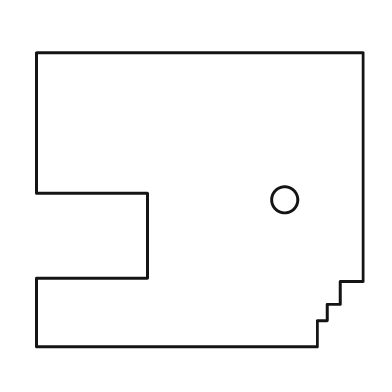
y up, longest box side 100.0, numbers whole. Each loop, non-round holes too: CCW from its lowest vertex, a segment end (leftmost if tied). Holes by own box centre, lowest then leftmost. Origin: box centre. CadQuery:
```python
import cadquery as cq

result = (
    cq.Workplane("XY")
    .moveTo(-50.0, -45.0)
    .lineTo(36.0, -45.0)
    .lineTo(36.0, -37.0)
    .lineTo(39.0, -37.0)
    .lineTo(39.0, -32.0)
    .lineTo(43.0, -32.0)
    .lineTo(43.0, -25.0)
    .lineTo(50.0, -25.0)
    .lineTo(50.0, 45.0)
    .lineTo(-50.0, 45.0)
    .lineTo(-50.0, 2.0)
    .lineTo(-16.0, 2.0)
    .lineTo(-16.0, -24.0)
    .lineTo(-50.0, -24.0)
    .close()
    .moveTo(26.0, 0.0)
    .circle(4.0)
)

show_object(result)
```